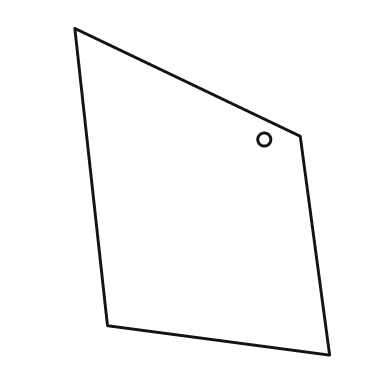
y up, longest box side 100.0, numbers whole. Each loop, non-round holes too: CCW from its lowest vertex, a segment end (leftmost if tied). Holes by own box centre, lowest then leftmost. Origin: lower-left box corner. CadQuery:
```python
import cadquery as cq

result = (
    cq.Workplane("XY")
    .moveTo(78.0, 0.0)
    .lineTo(69.0, 67.0)
    .lineTo(0.0, 100.0)
    .lineTo(10.0, 9.0)
    .close()
    .moveTo(58.0, 66.0)
    .circle(2.0)
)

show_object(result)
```